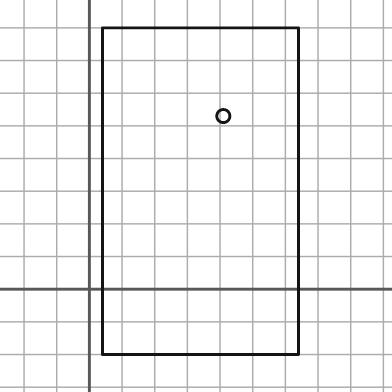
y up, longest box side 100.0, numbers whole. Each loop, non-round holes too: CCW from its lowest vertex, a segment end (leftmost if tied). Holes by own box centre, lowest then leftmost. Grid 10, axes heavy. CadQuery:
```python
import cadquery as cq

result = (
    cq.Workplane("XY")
    .moveTo(4.0, -20.0)
    .lineTo(64.0, -20.0)
    .lineTo(64.0, 80.0)
    .lineTo(4.0, 80.0)
    .close()
    .moveTo(41.0, 53.0)
    .circle(2.0)
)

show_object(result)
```